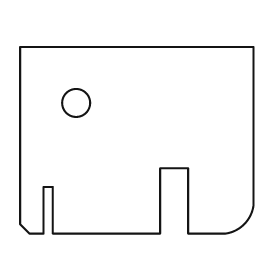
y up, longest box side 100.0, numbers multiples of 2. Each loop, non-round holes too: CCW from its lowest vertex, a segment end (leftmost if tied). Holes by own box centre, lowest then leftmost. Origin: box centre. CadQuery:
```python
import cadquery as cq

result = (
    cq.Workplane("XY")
    .moveTo(-46.0, -40.0)
    .lineTo(-40.0, -40.0)
    .lineTo(-40.0, -20.0)
    .lineTo(-36.0, -20.0)
    .lineTo(-36.0, -40.0)
    .lineTo(10.0, -40.0)
    .lineTo(10.0, -12.0)
    .lineTo(22.0, -12.0)
    .lineTo(22.0, -40.0)
    .lineTo(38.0, -40.0)
    .threePointArc((46.0, -36.0), (50.0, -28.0))
    .lineTo(50.0, 40.0)
    .lineTo(-50.0, 40.0)
    .lineTo(-50.0, -36.0)
    .close()
    .moveTo(-26.0, 16.0)
    .circle(6.0)
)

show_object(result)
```